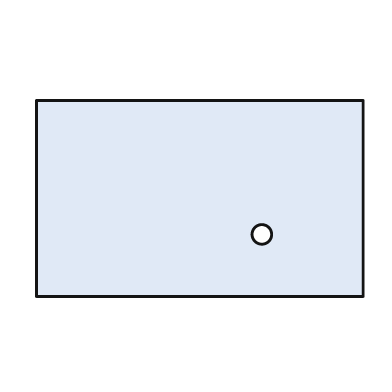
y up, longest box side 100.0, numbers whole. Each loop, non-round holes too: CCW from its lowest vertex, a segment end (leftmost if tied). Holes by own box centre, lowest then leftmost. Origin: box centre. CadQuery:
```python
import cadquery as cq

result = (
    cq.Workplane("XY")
    .moveTo(-50.0, -30.0)
    .lineTo(50.0, -30.0)
    .lineTo(50.0, 30.0)
    .lineTo(-50.0, 30.0)
    .close()
    .moveTo(19.0, -11.0)
    .circle(3.0)
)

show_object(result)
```